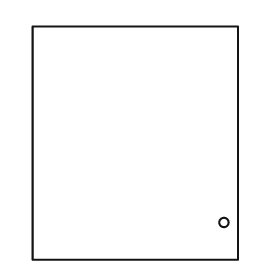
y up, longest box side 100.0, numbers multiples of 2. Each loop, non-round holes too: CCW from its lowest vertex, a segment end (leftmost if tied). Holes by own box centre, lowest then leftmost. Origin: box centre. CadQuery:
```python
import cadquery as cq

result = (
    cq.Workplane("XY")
    .moveTo(-44.0, -50.0)
    .lineTo(44.0, -50.0)
    .lineTo(44.0, 50.0)
    .lineTo(-44.0, 50.0)
    .close()
    .moveTo(38.0, -34.0)
    .circle(2.0)
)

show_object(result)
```